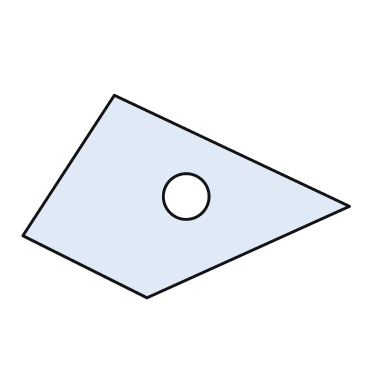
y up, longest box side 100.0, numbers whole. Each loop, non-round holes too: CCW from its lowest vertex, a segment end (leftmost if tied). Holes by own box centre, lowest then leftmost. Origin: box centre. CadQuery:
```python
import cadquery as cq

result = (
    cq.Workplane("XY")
    .moveTo(-12.0, -31.0)
    .lineTo(50.0, -3.0)
    .lineTo(-22.0, 31.0)
    .lineTo(-50.0, -12.0)
    .close()
    .moveTo(0.0, 0.0)
    .circle(7.0)
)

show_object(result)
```